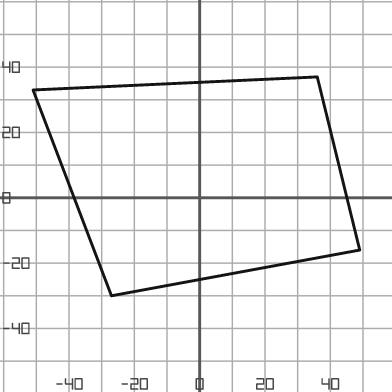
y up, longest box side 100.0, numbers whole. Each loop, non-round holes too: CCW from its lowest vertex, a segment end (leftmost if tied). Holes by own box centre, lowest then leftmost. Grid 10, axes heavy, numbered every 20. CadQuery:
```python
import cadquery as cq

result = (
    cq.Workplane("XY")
    .moveTo(-27.0, -30.0)
    .lineTo(49.0, -16.0)
    .lineTo(36.0, 37.0)
    .lineTo(-51.0, 33.0)
    .close()
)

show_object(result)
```